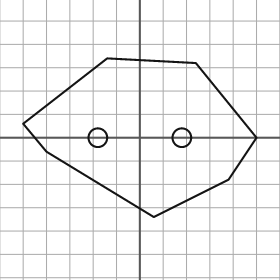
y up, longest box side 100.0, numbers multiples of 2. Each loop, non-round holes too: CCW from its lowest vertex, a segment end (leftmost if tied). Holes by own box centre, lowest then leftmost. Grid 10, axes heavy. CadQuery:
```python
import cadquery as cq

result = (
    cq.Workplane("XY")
    .moveTo(6.0, -34.0)
    .lineTo(38.0, -18.0)
    .lineTo(50.0, 0.0)
    .lineTo(24.0, 32.0)
    .lineTo(-14.0, 34.0)
    .lineTo(-50.0, 6.0)
    .lineTo(-40.0, -6.0)
    .close()
    .moveTo(-18.0, 0.0)
    .circle(4.0)
    .moveTo(18.0, 0.0)
    .circle(4.0)
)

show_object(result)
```